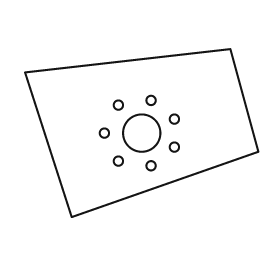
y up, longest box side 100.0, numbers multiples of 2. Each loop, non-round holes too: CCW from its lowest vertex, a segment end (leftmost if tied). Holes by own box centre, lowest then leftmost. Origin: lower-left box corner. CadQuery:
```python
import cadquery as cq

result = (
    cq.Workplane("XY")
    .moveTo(20.0, 0.0)
    .lineTo(100.0, 28.0)
    .lineTo(88.0, 72.0)
    .lineTo(0.0, 62.0)
    .close()
    .moveTo(54.0, 22.0)
    .circle(2.0)
    .moveTo(40.0, 24.0)
    .circle(2.0)
    .moveTo(64.0, 30.0)
    .circle(2.0)
    .moveTo(34.0, 36.0)
    .circle(2.0)
    .moveTo(50.0, 36.0)
    .circle(8.0)
    .moveTo(64.0, 42.0)
    .circle(2.0)
    .moveTo(40.0, 48.0)
    .circle(2.0)
    .moveTo(54.0, 50.0)
    .circle(2.0)
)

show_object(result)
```